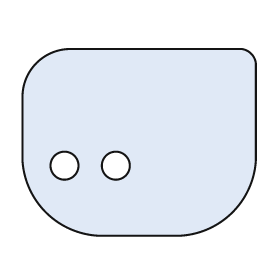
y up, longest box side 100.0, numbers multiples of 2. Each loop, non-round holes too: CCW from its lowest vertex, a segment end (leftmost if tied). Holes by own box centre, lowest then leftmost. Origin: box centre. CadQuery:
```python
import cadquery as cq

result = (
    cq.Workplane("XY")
    .moveTo(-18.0, -40.0)
    .lineTo(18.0, -40.0)
    .threePointArc((40.0, -30.0), (50.0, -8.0))
    .lineTo(50.0, 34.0)
    .threePointArc((48.0, 38.0), (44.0, 40.0))
    .lineTo(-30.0, 40.0)
    .threePointArc((-44.0, 34.0), (-50.0, 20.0))
    .lineTo(-50.0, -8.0)
    .threePointArc((-40.0, -30.0), (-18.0, -40.0))
    .close()
    .moveTo(-32.0, -10.0)
    .circle(6.0)
    .moveTo(-10.0, -10.0)
    .circle(6.0)
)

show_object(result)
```